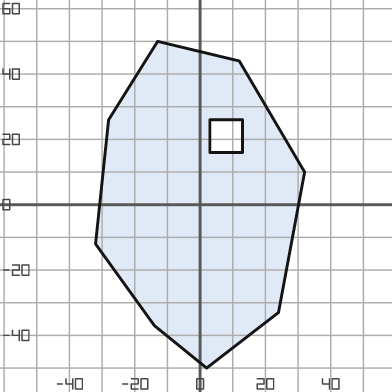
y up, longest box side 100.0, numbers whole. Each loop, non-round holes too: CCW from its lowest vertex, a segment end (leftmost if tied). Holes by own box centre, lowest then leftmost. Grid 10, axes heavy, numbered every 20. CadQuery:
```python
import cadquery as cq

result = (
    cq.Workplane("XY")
    .moveTo(2.0, -50.0)
    .lineTo(24.0, -33.0)
    .lineTo(32.0, 10.0)
    .lineTo(12.0, 44.0)
    .lineTo(-13.0, 50.0)
    .lineTo(-28.0, 26.0)
    .lineTo(-32.0, -12.0)
    .lineTo(-14.0, -37.0)
    .close()
    .moveTo(3.0, 16.0)
    .lineTo(13.0, 16.0)
    .lineTo(13.0, 26.0)
    .lineTo(3.0, 26.0)
    .close()
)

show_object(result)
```